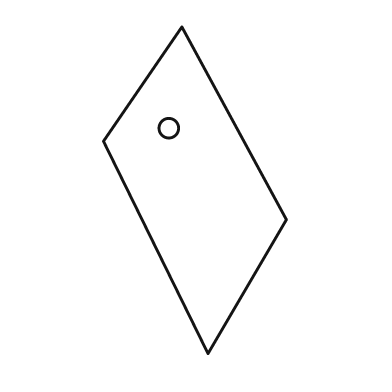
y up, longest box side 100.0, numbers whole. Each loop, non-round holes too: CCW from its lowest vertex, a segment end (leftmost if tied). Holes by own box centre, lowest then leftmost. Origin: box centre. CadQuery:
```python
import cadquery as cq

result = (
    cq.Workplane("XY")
    .moveTo(4.0, -50.0)
    .lineTo(28.0, -9.0)
    .lineTo(-4.0, 50.0)
    .lineTo(-28.0, 15.0)
    .close()
    .moveTo(-8.0, 19.0)
    .circle(3.0)
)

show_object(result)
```